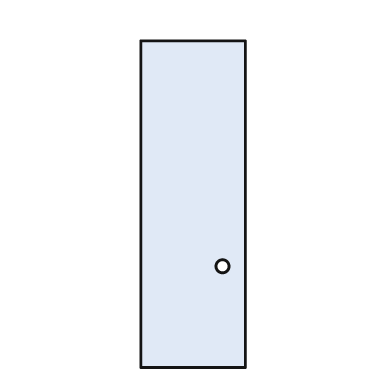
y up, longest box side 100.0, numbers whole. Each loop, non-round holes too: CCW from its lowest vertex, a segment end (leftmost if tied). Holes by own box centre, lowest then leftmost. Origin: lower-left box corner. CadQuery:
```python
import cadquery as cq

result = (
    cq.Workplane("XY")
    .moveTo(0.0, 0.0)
    .lineTo(32.0, 0.0)
    .lineTo(32.0, 100.0)
    .lineTo(0.0, 100.0)
    .close()
    .moveTo(25.0, 31.0)
    .circle(2.0)
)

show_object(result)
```